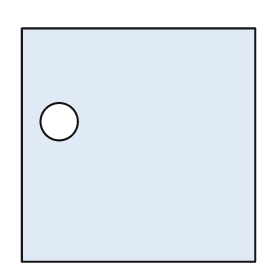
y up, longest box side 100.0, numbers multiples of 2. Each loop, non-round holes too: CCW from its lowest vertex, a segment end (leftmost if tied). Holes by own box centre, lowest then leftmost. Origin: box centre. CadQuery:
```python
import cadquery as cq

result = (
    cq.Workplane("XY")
    .moveTo(-50.0, -50.0)
    .lineTo(50.0, -50.0)
    .lineTo(50.0, 50.0)
    .lineTo(-50.0, 50.0)
    .close()
    .moveTo(-34.0, 10.0)
    .circle(8.0)
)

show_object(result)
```